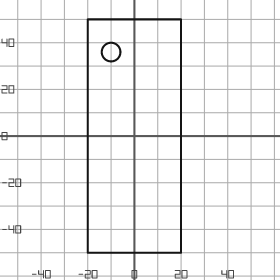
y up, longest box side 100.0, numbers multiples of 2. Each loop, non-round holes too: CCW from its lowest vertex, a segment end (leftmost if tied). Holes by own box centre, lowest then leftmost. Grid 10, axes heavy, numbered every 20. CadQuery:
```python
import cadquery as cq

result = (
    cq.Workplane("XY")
    .moveTo(-20.0, -50.0)
    .lineTo(20.0, -50.0)
    .lineTo(20.0, 50.0)
    .lineTo(-20.0, 50.0)
    .close()
    .moveTo(-10.0, 36.0)
    .circle(4.0)
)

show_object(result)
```